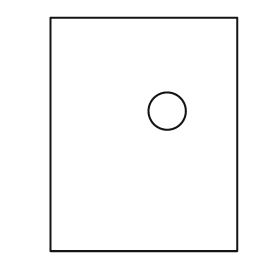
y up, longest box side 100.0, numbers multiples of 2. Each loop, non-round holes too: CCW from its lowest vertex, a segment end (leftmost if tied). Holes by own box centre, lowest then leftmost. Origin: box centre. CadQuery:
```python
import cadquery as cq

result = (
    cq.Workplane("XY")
    .moveTo(-40.0, -50.0)
    .lineTo(40.0, -50.0)
    .lineTo(40.0, 50.0)
    .lineTo(-40.0, 50.0)
    .close()
    .moveTo(10.0, 10.0)
    .circle(8.0)
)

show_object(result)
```